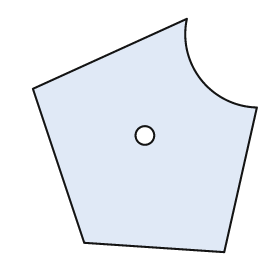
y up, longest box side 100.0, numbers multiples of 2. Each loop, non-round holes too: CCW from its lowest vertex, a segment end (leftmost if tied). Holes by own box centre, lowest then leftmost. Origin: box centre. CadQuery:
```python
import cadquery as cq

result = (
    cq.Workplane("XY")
    .moveTo(34.0, -50.0)
    .lineTo(48.0, 12.0)
    .threePointArc((24.0, 24.0), (18.0, 50.0))
    .lineTo(-48.0, 20.0)
    .lineTo(-26.0, -46.0)
    .close()
    .moveTo(0.0, 0.0)
    .circle(4.0)
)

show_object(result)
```